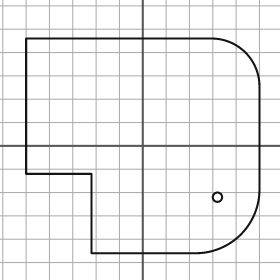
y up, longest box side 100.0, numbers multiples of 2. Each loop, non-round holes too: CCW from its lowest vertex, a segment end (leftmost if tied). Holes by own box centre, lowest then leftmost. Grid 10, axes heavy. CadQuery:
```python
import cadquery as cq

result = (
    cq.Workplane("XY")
    .moveTo(-22.0, -46.0)
    .lineTo(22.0, -46.0)
    .threePointArc((42.0, -38.0), (50.0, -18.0))
    .lineTo(50.0, 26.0)
    .threePointArc((44.0, 40.0), (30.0, 46.0))
    .lineTo(-50.0, 46.0)
    .lineTo(-50.0, -12.0)
    .lineTo(-22.0, -12.0)
    .close()
    .moveTo(32.0, -22.0)
    .circle(2.0)
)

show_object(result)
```